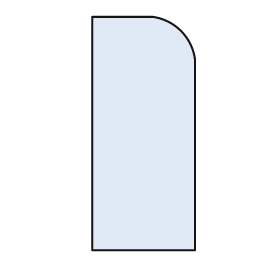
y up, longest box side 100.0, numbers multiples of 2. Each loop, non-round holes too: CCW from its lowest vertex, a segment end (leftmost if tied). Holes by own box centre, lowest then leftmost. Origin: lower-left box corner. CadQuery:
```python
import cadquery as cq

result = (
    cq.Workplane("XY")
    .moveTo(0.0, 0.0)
    .lineTo(44.0, 0.0)
    .lineTo(44.0, 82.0)
    .threePointArc((38.0, 94.0), (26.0, 100.0))
    .lineTo(0.0, 100.0)
    .close()
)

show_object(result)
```